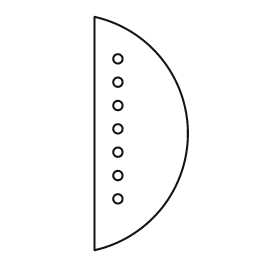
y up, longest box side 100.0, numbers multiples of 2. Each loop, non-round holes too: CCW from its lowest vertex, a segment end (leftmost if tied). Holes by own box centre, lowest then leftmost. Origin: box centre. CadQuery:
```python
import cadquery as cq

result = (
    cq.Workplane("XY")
    .moveTo(-20.0, -50.0)
    .threePointArc((20.0, 0.0), (-20.0, 50.0))
    .close()
    .moveTo(-10.0, -28.0)
    .circle(2.0)
    .moveTo(-10.0, -18.0)
    .circle(2.0)
    .moveTo(-10.0, -8.0)
    .circle(2.0)
    .moveTo(-10.0, 2.0)
    .circle(2.0)
    .moveTo(-10.0, 12.0)
    .circle(2.0)
    .moveTo(-10.0, 22.0)
    .circle(2.0)
    .moveTo(-10.0, 32.0)
    .circle(2.0)
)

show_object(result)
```